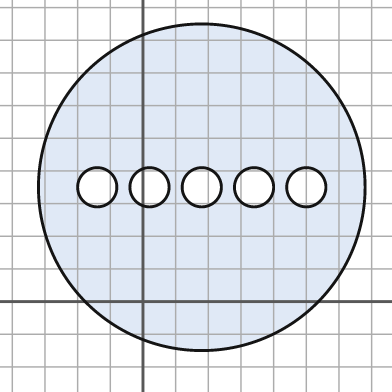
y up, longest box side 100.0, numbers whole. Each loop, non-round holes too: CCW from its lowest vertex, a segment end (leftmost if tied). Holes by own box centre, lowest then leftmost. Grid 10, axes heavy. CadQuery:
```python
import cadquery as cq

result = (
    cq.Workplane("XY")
    .moveTo(18.0, 35.0)
    .circle(50.0)
    .moveTo(-14.0, 35.0)
    .circle(6.0)
    .moveTo(2.0, 35.0)
    .circle(6.0)
    .moveTo(18.0, 35.0)
    .circle(6.0)
    .moveTo(34.0, 35.0)
    .circle(6.0)
    .moveTo(50.0, 35.0)
    .circle(6.0)
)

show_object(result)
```